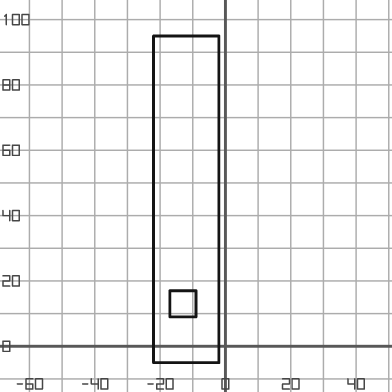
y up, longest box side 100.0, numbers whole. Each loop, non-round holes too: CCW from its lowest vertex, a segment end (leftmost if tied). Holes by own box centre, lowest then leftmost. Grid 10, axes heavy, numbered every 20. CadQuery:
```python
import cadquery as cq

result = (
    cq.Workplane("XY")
    .moveTo(-22.0, -5.0)
    .lineTo(-2.0, -5.0)
    .lineTo(-2.0, 95.0)
    .lineTo(-22.0, 95.0)
    .close()
    .moveTo(-17.0, 9.0)
    .lineTo(-9.0, 9.0)
    .lineTo(-9.0, 17.0)
    .lineTo(-17.0, 17.0)
    .close()
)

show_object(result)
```